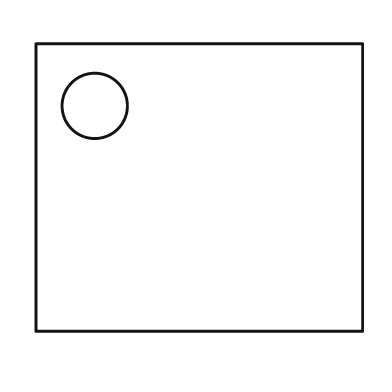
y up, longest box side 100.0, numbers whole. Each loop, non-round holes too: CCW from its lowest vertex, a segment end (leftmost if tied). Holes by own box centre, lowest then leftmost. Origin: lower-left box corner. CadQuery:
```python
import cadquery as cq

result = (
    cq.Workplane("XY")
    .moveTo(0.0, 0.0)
    .lineTo(100.0, 0.0)
    .lineTo(100.0, 88.0)
    .lineTo(0.0, 88.0)
    .close()
    .moveTo(18.0, 69.0)
    .circle(10.0)
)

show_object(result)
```